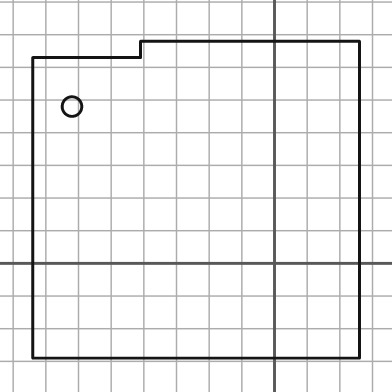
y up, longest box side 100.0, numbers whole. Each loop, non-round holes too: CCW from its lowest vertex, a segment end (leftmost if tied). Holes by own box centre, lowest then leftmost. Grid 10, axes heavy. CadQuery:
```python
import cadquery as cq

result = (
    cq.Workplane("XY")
    .moveTo(-74.0, -29.0)
    .lineTo(26.0, -29.0)
    .lineTo(26.0, 68.0)
    .lineTo(-41.0, 68.0)
    .lineTo(-41.0, 63.0)
    .lineTo(-74.0, 63.0)
    .close()
    .moveTo(-62.0, 48.0)
    .circle(3.0)
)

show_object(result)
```